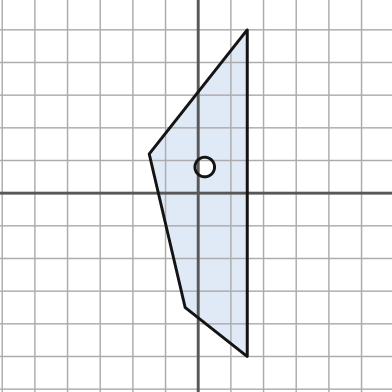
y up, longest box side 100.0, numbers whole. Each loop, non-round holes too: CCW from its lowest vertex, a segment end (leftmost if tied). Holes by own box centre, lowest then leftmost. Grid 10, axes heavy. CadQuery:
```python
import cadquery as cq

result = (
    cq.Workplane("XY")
    .moveTo(15.0, -50.0)
    .lineTo(15.0, 50.0)
    .lineTo(-15.0, 12.0)
    .lineTo(-4.0, -35.0)
    .close()
    .moveTo(2.0, 8.0)
    .circle(3.0)
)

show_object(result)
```